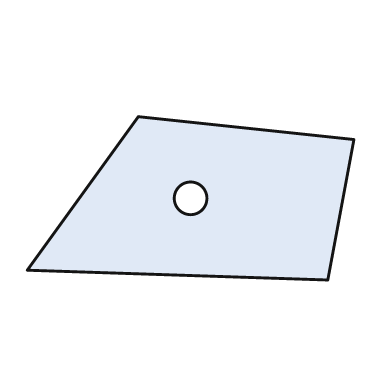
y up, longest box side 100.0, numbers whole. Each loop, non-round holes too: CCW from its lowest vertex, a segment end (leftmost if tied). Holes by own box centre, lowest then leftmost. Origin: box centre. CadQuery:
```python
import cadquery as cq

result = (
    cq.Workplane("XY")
    .moveTo(42.0, -25.0)
    .lineTo(50.0, 18.0)
    .lineTo(-16.0, 25.0)
    .lineTo(-50.0, -22.0)
    .close()
    .moveTo(0.0, 0.0)
    .circle(5.0)
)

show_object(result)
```